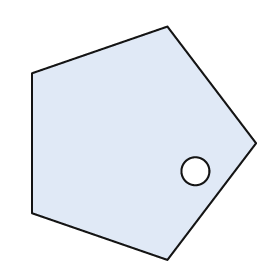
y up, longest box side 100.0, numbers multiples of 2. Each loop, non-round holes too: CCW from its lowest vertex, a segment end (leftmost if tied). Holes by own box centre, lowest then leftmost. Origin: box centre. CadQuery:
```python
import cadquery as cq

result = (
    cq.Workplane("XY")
    .moveTo(10.0, -50.0)
    .lineTo(48.0, 0.0)
    .lineTo(10.0, 50.0)
    .lineTo(-48.0, 30.0)
    .lineTo(-48.0, -30.0)
    .close()
    .moveTo(22.0, -12.0)
    .circle(6.0)
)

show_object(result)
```